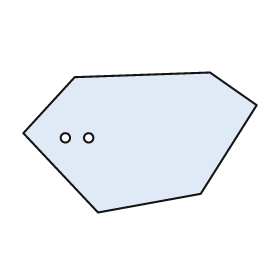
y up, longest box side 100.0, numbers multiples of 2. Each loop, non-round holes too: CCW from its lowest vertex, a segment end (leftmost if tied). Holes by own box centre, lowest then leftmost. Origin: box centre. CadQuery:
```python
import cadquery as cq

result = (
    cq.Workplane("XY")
    .moveTo(-18.0, -30.0)
    .lineTo(26.0, -22.0)
    .lineTo(50.0, 16.0)
    .lineTo(30.0, 30.0)
    .lineTo(-28.0, 28.0)
    .lineTo(-50.0, 4.0)
    .close()
    .moveTo(-32.0, 2.0)
    .circle(2.0)
    .moveTo(-22.0, 2.0)
    .circle(2.0)
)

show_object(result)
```